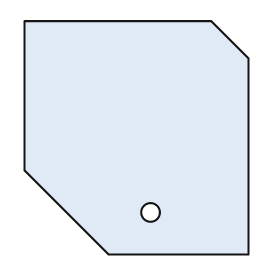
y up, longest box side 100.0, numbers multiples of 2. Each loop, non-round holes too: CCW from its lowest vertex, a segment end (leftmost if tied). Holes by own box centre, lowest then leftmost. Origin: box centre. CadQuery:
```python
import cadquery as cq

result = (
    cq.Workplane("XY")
    .moveTo(-12.0, -50.0)
    .lineTo(48.0, -50.0)
    .lineTo(48.0, 34.0)
    .lineTo(32.0, 50.0)
    .lineTo(-48.0, 50.0)
    .lineTo(-48.0, -14.0)
    .close()
    .moveTo(6.0, -32.0)
    .circle(4.0)
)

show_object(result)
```